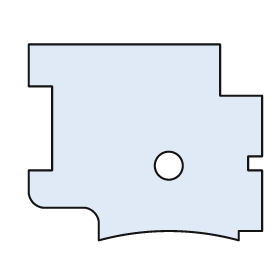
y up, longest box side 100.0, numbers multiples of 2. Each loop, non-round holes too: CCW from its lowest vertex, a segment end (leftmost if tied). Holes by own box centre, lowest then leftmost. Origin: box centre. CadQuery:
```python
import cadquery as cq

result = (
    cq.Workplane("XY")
    .moveTo(-20.0, -42.0)
    .threePointArc((10.0, -38.0), (40.0, -42.0))
    .lineTo(40.0, -38.0)
    .lineTo(50.0, -38.0)
    .lineTo(50.0, -12.0)
    .lineTo(44.0, -12.0)
    .lineTo(44.0, -6.0)
    .lineTo(50.0, -6.0)
    .lineTo(50.0, 20.0)
    .lineTo(32.0, 20.0)
    .lineTo(32.0, 42.0)
    .lineTo(-50.0, 42.0)
    .lineTo(-50.0, 24.0)
    .lineTo(-40.0, 24.0)
    .lineTo(-40.0, -12.0)
    .lineTo(-50.0, -12.0)
    .lineTo(-50.0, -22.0)
    .threePointArc((-48.0, -26.0), (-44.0, -28.0))
    .lineTo(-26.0, -28.0)
    .threePointArc((-22.0, -30.0), (-20.0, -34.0))
    .close()
    .moveTo(10.0, -10.0)
    .circle(6.0)
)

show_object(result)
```